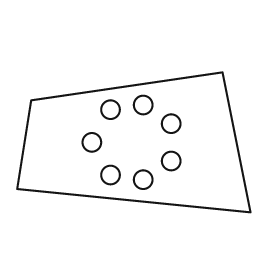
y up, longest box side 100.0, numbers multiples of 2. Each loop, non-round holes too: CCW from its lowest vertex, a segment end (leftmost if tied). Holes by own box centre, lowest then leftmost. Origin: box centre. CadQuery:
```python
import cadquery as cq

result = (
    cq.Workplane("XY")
    .moveTo(50.0, -30.0)
    .lineTo(38.0, 30.0)
    .lineTo(-44.0, 18.0)
    .lineTo(-50.0, -20.0)
    .close()
    .moveTo(4.0, -16.0)
    .circle(4.0)
    .moveTo(-10.0, -14.0)
    .circle(4.0)
    .moveTo(16.0, -8.0)
    .circle(4.0)
    .moveTo(-18.0, 0.0)
    .circle(4.0)
    .moveTo(16.0, 8.0)
    .circle(4.0)
    .moveTo(-10.0, 14.0)
    .circle(4.0)
    .moveTo(4.0, 16.0)
    .circle(4.0)
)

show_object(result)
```